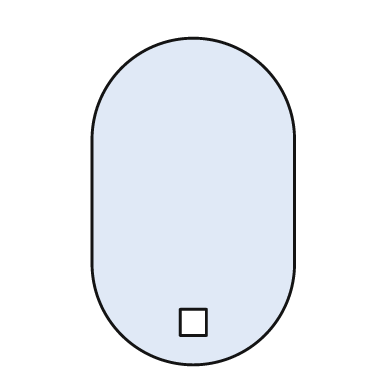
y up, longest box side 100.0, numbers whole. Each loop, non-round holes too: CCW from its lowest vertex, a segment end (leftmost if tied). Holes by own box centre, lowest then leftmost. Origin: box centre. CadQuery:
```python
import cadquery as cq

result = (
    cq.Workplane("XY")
    .moveTo(-31.0, -19.0)
    .threePointArc((0.0, -50.0), (31.0, -19.0))
    .lineTo(31.0, 19.0)
    .threePointArc((0.0, 50.0), (-31.0, 19.0))
    .close()
    .moveTo(-4.0, -41.0)
    .lineTo(4.0, -41.0)
    .lineTo(4.0, -33.0)
    .lineTo(-4.0, -33.0)
    .close()
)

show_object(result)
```